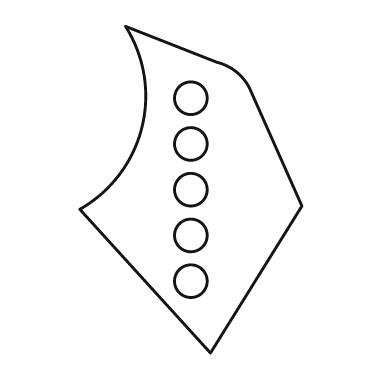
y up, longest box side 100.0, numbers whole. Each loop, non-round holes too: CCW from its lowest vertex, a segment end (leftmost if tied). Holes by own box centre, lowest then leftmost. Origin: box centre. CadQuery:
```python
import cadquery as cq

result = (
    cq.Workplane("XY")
    .moveTo(6.0, -50.0)
    .lineTo(34.0, -5.0)
    .lineTo(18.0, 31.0)
    .threePointArc((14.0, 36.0), (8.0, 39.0))
    .lineTo(-20.0, 50.0)
    .threePointArc((-15.0, 19.0), (-34.0, -6.0))
    .close()
    .moveTo(0.0, -28.0)
    .circle(5.0)
    .moveTo(0.0, -14.0)
    .circle(5.0)
    .moveTo(0.0, 0.0)
    .circle(5.0)
    .moveTo(0.0, 14.0)
    .circle(5.0)
    .moveTo(0.0, 28.0)
    .circle(5.0)
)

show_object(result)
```